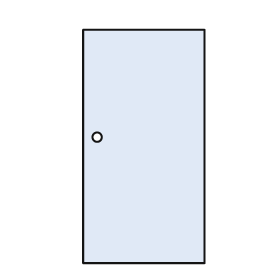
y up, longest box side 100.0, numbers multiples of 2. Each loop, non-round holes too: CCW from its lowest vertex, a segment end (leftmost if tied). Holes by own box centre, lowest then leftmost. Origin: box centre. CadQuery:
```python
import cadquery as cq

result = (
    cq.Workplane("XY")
    .moveTo(-26.0, -50.0)
    .lineTo(26.0, -50.0)
    .lineTo(26.0, 50.0)
    .lineTo(-26.0, 50.0)
    .close()
    .moveTo(-20.0, 4.0)
    .circle(2.0)
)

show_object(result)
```